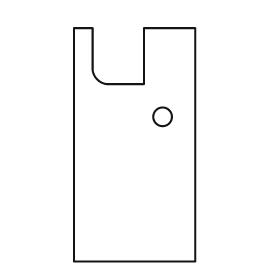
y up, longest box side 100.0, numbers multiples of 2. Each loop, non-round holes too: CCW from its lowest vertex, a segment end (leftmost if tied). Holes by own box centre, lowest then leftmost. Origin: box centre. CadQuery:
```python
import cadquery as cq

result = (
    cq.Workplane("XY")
    .moveTo(-26.0, -50.0)
    .lineTo(26.0, -50.0)
    .lineTo(26.0, 50.0)
    .lineTo(4.0, 50.0)
    .lineTo(4.0, 26.0)
    .lineTo(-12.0, 26.0)
    .threePointArc((-16.0, 28.0), (-18.0, 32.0))
    .lineTo(-18.0, 50.0)
    .lineTo(-26.0, 50.0)
    .close()
    .moveTo(12.0, 12.0)
    .circle(4.0)
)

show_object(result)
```